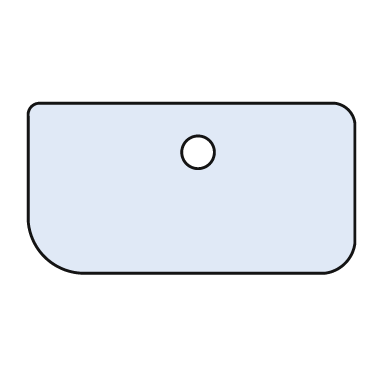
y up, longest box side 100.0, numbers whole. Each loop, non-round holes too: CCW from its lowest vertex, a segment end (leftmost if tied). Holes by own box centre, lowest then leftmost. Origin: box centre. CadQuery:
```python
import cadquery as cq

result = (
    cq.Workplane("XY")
    .moveTo(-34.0, -26.0)
    .lineTo(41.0, -26.0)
    .threePointArc((47.0, -23.0), (50.0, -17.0))
    .lineTo(50.0, 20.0)
    .threePointArc((48.0, 24.0), (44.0, 26.0))
    .lineTo(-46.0, 26.0)
    .threePointArc((-49.0, 25.0), (-50.0, 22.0))
    .lineTo(-50.0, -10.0)
    .threePointArc((-45.0, -21.0), (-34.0, -26.0))
    .close()
    .moveTo(2.0, 11.0)
    .circle(5.0)
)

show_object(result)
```